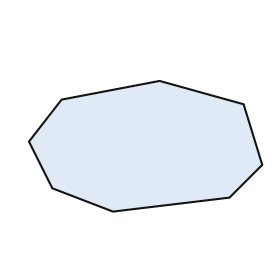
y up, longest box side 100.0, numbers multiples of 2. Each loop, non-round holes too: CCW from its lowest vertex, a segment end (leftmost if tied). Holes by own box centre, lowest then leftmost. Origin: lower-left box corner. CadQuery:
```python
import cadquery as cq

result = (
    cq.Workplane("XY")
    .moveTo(36.0, 0.0)
    .lineTo(86.0, 6.0)
    .lineTo(100.0, 20.0)
    .lineTo(92.0, 46.0)
    .lineTo(56.0, 56.0)
    .lineTo(14.0, 48.0)
    .lineTo(0.0, 30.0)
    .lineTo(10.0, 10.0)
    .close()
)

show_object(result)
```